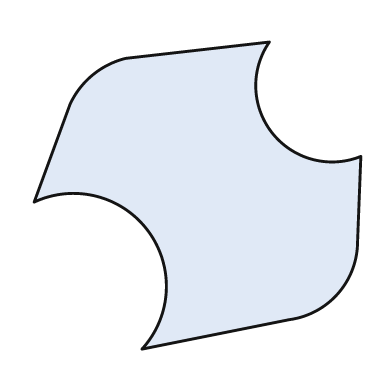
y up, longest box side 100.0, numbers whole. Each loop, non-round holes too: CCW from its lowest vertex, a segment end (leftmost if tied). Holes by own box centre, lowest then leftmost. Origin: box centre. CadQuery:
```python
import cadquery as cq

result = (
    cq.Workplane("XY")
    .moveTo(-17.0, -47.0)
    .lineTo(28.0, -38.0)
    .threePointArc((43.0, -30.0), (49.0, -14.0))
    .lineTo(50.0, 12.0)
    .threePointArc((23.0, 19.0), (22.0, 47.0))
    .lineTo(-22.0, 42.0)
    .threePointArc((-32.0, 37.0), (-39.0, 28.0))
    .lineTo(-50.0, -2.0)
    .threePointArc((-15.0, -11.0), (-17.0, -47.0))
    .close()
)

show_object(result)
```